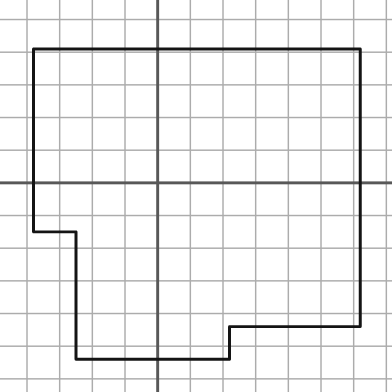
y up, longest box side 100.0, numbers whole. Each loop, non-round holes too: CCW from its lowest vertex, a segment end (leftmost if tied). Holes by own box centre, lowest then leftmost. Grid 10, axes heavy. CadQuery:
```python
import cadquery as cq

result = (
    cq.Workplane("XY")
    .moveTo(-25.0, -54.0)
    .lineTo(22.0, -54.0)
    .lineTo(22.0, -44.0)
    .lineTo(62.0, -44.0)
    .lineTo(62.0, 41.0)
    .lineTo(-38.0, 41.0)
    .lineTo(-38.0, -15.0)
    .lineTo(-25.0, -15.0)
    .close()
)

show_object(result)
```